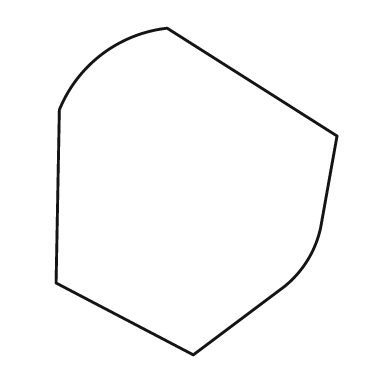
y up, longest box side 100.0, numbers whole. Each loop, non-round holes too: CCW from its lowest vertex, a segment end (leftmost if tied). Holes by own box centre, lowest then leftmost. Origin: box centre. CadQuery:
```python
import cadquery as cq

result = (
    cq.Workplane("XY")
    .moveTo(-1.0, -50.0)
    .lineTo(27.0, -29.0)
    .threePointArc((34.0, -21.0), (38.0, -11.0))
    .lineTo(43.0, 17.0)
    .lineTo(-9.0, 50.0)
    .threePointArc((-29.0, 42.0), (-42.0, 25.0))
    .lineTo(-43.0, -28.0)
    .close()
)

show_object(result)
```